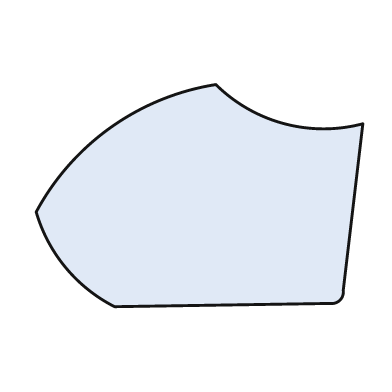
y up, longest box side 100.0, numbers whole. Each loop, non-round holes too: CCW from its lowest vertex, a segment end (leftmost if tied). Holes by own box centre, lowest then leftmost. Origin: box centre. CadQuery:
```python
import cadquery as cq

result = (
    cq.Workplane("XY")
    .moveTo(-26.0, -34.0)
    .lineTo(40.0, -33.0)
    .threePointArc((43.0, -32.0), (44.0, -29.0))
    .lineTo(50.0, 22.0)
    .threePointArc((26.0, 22.0), (5.0, 34.0))
    .threePointArc((-27.0, 21.0), (-50.0, -5.0))
    .threePointArc((-41.0, -22.0), (-26.0, -34.0))
    .close()
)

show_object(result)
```